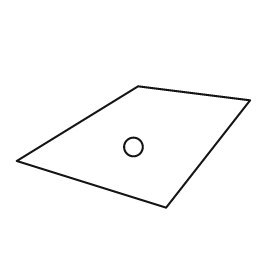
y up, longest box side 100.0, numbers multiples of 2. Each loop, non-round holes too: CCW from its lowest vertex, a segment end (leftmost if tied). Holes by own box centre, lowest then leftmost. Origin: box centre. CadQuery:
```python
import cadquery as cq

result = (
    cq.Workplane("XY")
    .moveTo(14.0, -26.0)
    .lineTo(50.0, 20.0)
    .lineTo(2.0, 26.0)
    .lineTo(-50.0, -6.0)
    .close()
    .moveTo(0.0, 0.0)
    .circle(4.0)
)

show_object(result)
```